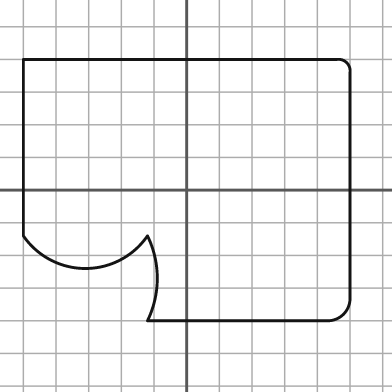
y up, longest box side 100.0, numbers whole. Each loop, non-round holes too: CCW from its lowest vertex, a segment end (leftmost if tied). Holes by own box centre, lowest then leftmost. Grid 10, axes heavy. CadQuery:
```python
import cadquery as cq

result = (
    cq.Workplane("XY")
    .moveTo(-12.0, -40.0)
    .lineTo(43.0, -40.0)
    .threePointArc((48.0, -38.0), (50.0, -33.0))
    .lineTo(50.0, 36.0)
    .threePointArc((49.0, 39.0), (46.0, 40.0))
    .lineTo(-50.0, 40.0)
    .lineTo(-50.0, -14.0)
    .threePointArc((-31.0, -24.0), (-12.0, -14.0))
    .threePointArc((-9.0, -27.0), (-12.0, -40.0))
    .close()
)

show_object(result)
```